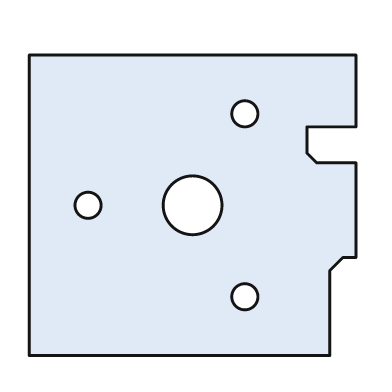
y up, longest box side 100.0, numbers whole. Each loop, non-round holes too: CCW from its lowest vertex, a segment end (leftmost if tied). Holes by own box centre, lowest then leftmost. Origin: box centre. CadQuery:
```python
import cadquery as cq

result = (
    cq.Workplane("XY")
    .moveTo(-50.0, -46.0)
    .lineTo(42.0, -46.0)
    .lineTo(42.0, -20.0)
    .lineTo(46.0, -16.0)
    .lineTo(50.0, -16.0)
    .lineTo(50.0, 13.0)
    .lineTo(38.0, 13.0)
    .lineTo(35.0, 16.0)
    .lineTo(35.0, 24.0)
    .lineTo(50.0, 24.0)
    .lineTo(50.0, 46.0)
    .lineTo(-50.0, 46.0)
    .close()
    .moveTo(16.0, -28.0)
    .circle(4.0)
    .moveTo(-32.0, 0.0)
    .circle(4.0)
    .moveTo(0.0, 0.0)
    .circle(9.0)
    .moveTo(16.0, 28.0)
    .circle(4.0)
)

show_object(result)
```